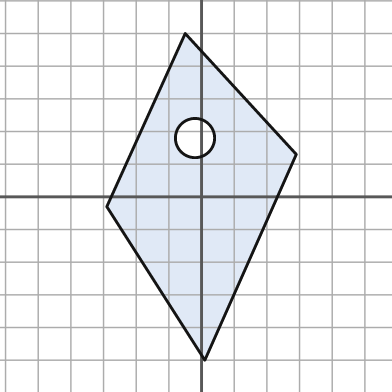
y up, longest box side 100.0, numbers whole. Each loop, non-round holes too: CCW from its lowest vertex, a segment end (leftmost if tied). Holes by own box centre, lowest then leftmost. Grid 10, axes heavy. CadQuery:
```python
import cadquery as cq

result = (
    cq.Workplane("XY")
    .moveTo(1.0, -50.0)
    .lineTo(29.0, 13.0)
    .lineTo(-5.0, 50.0)
    .lineTo(-29.0, -3.0)
    .close()
    .moveTo(-2.0, 18.0)
    .circle(6.0)
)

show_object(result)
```